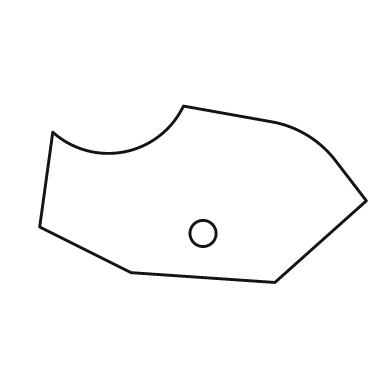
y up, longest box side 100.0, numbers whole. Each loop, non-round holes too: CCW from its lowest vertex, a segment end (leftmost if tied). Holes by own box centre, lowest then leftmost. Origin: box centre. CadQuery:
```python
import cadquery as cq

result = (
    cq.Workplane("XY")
    .moveTo(22.0, -27.0)
    .lineTo(50.0, -2.0)
    .lineTo(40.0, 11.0)
    .threePointArc((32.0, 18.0), (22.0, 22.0))
    .lineTo(-6.0, 27.0)
    .threePointArc((-24.0, 13.0), (-46.0, 19.0))
    .lineTo(-50.0, -10.0)
    .lineTo(-22.0, -24.0)
    .close()
    .moveTo(0.0, -12.0)
    .circle(4.0)
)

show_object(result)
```